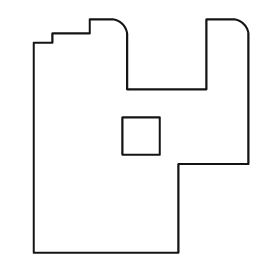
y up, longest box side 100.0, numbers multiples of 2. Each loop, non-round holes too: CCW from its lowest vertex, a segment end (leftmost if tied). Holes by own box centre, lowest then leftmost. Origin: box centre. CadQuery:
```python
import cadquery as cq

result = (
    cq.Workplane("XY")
    .moveTo(-46.0, -50.0)
    .lineTo(16.0, -50.0)
    .lineTo(16.0, -12.0)
    .lineTo(46.0, -12.0)
    .lineTo(46.0, 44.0)
    .threePointArc((44.0, 48.0), (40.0, 50.0))
    .lineTo(28.0, 50.0)
    .lineTo(28.0, 20.0)
    .lineTo(-6.0, 20.0)
    .lineTo(-6.0, 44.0)
    .threePointArc((-8.0, 48.0), (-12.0, 50.0))
    .lineTo(-22.0, 50.0)
    .lineTo(-22.0, 44.0)
    .lineTo(-38.0, 44.0)
    .lineTo(-38.0, 40.0)
    .lineTo(-46.0, 40.0)
    .close()
    .moveTo(-8.0, -8.0)
    .lineTo(8.0, -8.0)
    .lineTo(8.0, 8.0)
    .lineTo(-8.0, 8.0)
    .close()
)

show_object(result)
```